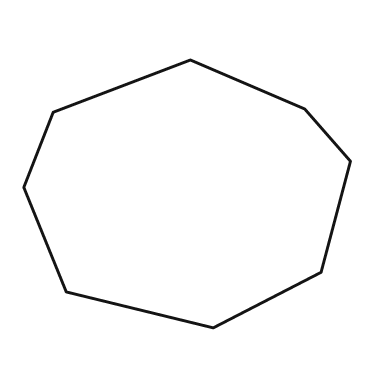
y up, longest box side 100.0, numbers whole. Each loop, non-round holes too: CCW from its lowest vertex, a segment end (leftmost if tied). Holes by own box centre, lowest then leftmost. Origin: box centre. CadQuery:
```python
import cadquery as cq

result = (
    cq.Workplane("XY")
    .moveTo(8.0, -41.0)
    .lineTo(41.0, -24.0)
    .lineTo(50.0, 10.0)
    .lineTo(36.0, 26.0)
    .lineTo(1.0, 41.0)
    .lineTo(-41.0, 25.0)
    .lineTo(-50.0, 2.0)
    .lineTo(-37.0, -30.0)
    .close()
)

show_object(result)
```